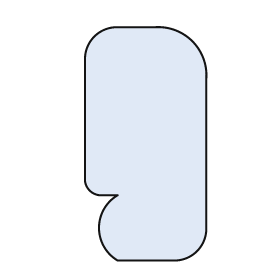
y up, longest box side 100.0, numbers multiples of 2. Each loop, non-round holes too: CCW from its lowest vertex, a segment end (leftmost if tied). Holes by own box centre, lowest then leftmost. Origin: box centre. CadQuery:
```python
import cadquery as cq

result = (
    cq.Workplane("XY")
    .moveTo(-12.0, -50.0)
    .lineTo(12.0, -50.0)
    .threePointArc((22.0, -46.0), (26.0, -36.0))
    .lineTo(26.0, 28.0)
    .threePointArc((20.0, 44.0), (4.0, 50.0))
    .lineTo(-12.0, 50.0)
    .threePointArc((-22.0, 46.0), (-26.0, 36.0))
    .lineTo(-26.0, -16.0)
    .threePointArc((-24.0, -20.0), (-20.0, -22.0))
    .lineTo(-12.0, -22.0)
    .threePointArc((-20.0, -36.0), (-12.0, -50.0))
    .close()
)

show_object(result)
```